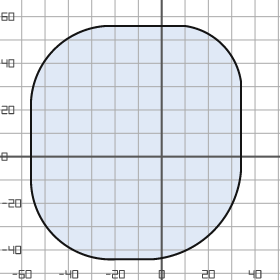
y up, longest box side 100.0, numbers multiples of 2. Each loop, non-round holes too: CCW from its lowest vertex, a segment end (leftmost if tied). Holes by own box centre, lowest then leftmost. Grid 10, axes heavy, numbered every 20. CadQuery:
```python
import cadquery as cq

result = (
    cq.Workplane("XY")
    .moveTo(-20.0, -44.0)
    .lineTo(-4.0, -44.0)
    .threePointArc((22.0, -32.0), (34.0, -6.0))
    .lineTo(34.0, 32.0)
    .threePointArc((26.0, 48.0), (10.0, 56.0))
    .lineTo(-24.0, 56.0)
    .threePointArc((-46.0, 46.0), (-56.0, 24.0))
    .lineTo(-56.0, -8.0)
    .threePointArc((-46.0, -34.0), (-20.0, -44.0))
    .close()
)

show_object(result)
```